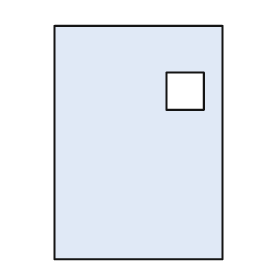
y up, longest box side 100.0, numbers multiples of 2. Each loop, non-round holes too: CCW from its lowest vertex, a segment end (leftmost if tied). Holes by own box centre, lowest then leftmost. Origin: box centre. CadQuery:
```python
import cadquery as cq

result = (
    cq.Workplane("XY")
    .moveTo(-36.0, -50.0)
    .lineTo(36.0, -50.0)
    .lineTo(36.0, 50.0)
    .lineTo(-36.0, 50.0)
    .close()
    .moveTo(12.0, 14.0)
    .lineTo(28.0, 14.0)
    .lineTo(28.0, 30.0)
    .lineTo(12.0, 30.0)
    .close()
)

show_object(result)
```